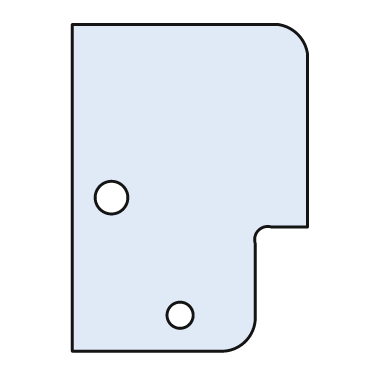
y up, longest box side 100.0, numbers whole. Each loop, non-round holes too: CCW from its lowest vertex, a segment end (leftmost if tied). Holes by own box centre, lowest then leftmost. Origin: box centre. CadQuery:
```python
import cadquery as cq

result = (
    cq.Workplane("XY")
    .moveTo(-36.0, -50.0)
    .lineTo(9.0, -50.0)
    .threePointArc((17.0, -47.0), (20.0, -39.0))
    .lineTo(20.0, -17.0)
    .threePointArc((21.0, -13.0), (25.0, -12.0))
    .lineTo(36.0, -12.0)
    .lineTo(36.0, 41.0)
    .threePointArc((33.0, 47.0), (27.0, 50.0))
    .lineTo(-36.0, 50.0)
    .close()
    .moveTo(-3.0, -39.0)
    .circle(4.0)
    .moveTo(-24.0, -3.0)
    .circle(5.0)
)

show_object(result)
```